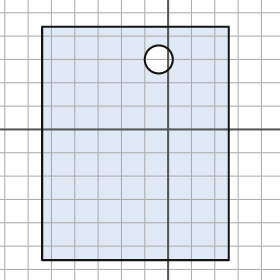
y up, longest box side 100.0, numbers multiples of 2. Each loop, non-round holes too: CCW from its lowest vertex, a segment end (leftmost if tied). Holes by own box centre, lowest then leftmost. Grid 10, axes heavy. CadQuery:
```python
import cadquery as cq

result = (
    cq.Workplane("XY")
    .moveTo(-54.0, -56.0)
    .lineTo(26.0, -56.0)
    .lineTo(26.0, 44.0)
    .lineTo(-54.0, 44.0)
    .close()
    .moveTo(-4.0, 30.0)
    .circle(6.0)
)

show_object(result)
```